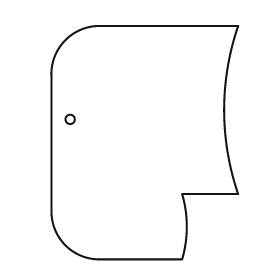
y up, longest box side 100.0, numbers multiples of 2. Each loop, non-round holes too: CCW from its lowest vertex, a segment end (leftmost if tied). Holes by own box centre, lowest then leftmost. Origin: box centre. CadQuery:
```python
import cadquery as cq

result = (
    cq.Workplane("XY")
    .moveTo(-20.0, -50.0)
    .lineTo(16.0, -50.0)
    .threePointArc((18.0, -36.0), (16.0, -22.0))
    .lineTo(40.0, -22.0)
    .threePointArc((34.0, 14.0), (40.0, 50.0))
    .lineTo(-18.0, 50.0)
    .threePointArc((-34.0, 44.0), (-40.0, 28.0))
    .lineTo(-40.0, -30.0)
    .threePointArc((-34.0, -44.0), (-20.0, -50.0))
    .close()
    .moveTo(-32.0, 10.0)
    .circle(2.0)
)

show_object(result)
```